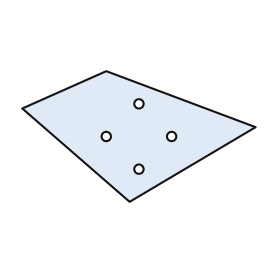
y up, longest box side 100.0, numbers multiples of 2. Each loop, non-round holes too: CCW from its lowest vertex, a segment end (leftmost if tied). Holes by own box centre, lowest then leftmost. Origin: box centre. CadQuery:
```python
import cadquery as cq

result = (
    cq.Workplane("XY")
    .moveTo(-4.0, -28.0)
    .lineTo(50.0, 4.0)
    .lineTo(-14.0, 28.0)
    .lineTo(-50.0, 12.0)
    .close()
    .moveTo(0.0, -14.0)
    .circle(2.0)
    .moveTo(-14.0, 0.0)
    .circle(2.0)
    .moveTo(14.0, 0.0)
    .circle(2.0)
    .moveTo(0.0, 14.0)
    .circle(2.0)
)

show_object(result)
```